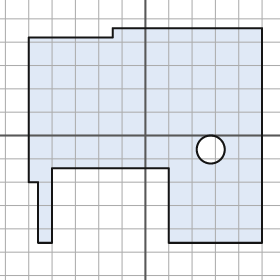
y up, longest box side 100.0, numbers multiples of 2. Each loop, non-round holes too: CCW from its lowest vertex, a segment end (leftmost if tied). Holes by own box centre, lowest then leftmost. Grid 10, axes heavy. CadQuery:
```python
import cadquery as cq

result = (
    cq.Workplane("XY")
    .moveTo(-46.0, -46.0)
    .lineTo(-40.0, -46.0)
    .lineTo(-40.0, -14.0)
    .lineTo(10.0, -14.0)
    .lineTo(10.0, -46.0)
    .lineTo(50.0, -46.0)
    .lineTo(50.0, 46.0)
    .lineTo(-14.0, 46.0)
    .lineTo(-14.0, 42.0)
    .lineTo(-50.0, 42.0)
    .lineTo(-50.0, -20.0)
    .lineTo(-46.0, -20.0)
    .close()
    .moveTo(28.0, -6.0)
    .circle(6.0)
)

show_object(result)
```